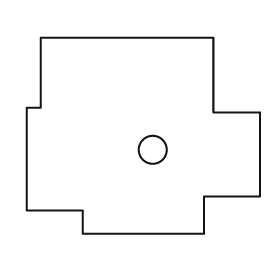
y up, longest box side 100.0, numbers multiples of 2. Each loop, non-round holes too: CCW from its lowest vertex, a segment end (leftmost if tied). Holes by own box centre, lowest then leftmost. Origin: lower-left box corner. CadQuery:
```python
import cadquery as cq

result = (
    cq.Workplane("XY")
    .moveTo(24.0, 0.0)
    .lineTo(76.0, 0.0)
    .lineTo(76.0, 16.0)
    .lineTo(100.0, 16.0)
    .lineTo(100.0, 52.0)
    .lineTo(80.0, 52.0)
    .lineTo(80.0, 84.0)
    .lineTo(6.0, 84.0)
    .lineTo(6.0, 54.0)
    .lineTo(0.0, 54.0)
    .lineTo(0.0, 10.0)
    .lineTo(24.0, 10.0)
    .close()
    .moveTo(54.0, 36.0)
    .circle(6.0)
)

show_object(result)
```